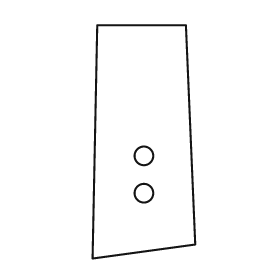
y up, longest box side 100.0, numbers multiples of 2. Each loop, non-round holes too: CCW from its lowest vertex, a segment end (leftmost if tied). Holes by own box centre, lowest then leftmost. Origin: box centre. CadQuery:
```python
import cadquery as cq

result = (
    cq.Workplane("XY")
    .moveTo(-22.0, -50.0)
    .lineTo(22.0, -44.0)
    .lineTo(18.0, 50.0)
    .lineTo(-20.0, 50.0)
    .close()
    .moveTo(0.0, -22.0)
    .circle(4.0)
    .moveTo(0.0, -6.0)
    .circle(4.0)
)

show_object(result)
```